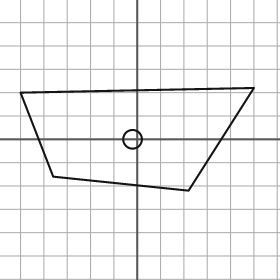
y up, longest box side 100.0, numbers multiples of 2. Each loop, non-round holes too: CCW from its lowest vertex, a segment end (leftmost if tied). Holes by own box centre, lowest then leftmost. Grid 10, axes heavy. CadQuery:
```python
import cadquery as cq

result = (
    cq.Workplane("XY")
    .moveTo(22.0, -22.0)
    .lineTo(50.0, 22.0)
    .lineTo(-50.0, 20.0)
    .lineTo(-36.0, -16.0)
    .close()
    .moveTo(-2.0, 0.0)
    .circle(4.0)
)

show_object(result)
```